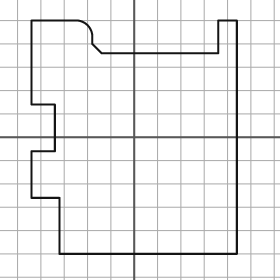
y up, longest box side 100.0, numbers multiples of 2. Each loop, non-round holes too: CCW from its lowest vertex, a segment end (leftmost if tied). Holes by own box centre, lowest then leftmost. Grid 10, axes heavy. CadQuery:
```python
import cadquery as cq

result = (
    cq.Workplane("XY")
    .moveTo(-32.0, -50.0)
    .lineTo(44.0, -50.0)
    .lineTo(44.0, 50.0)
    .lineTo(36.0, 50.0)
    .lineTo(36.0, 36.0)
    .lineTo(-14.0, 36.0)
    .lineTo(-18.0, 40.0)
    .lineTo(-18.0, 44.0)
    .threePointArc((-20.0, 48.0), (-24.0, 50.0))
    .lineTo(-44.0, 50.0)
    .lineTo(-44.0, 14.0)
    .lineTo(-34.0, 14.0)
    .lineTo(-34.0, -6.0)
    .lineTo(-44.0, -6.0)
    .lineTo(-44.0, -26.0)
    .lineTo(-32.0, -26.0)
    .close()
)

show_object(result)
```